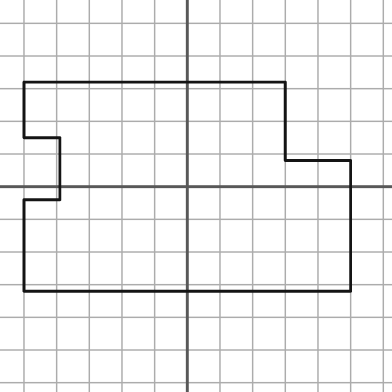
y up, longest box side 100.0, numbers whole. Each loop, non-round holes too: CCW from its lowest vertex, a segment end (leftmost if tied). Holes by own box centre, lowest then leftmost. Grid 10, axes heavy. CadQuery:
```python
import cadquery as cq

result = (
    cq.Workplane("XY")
    .moveTo(-50.0, -32.0)
    .lineTo(50.0, -32.0)
    .lineTo(50.0, 8.0)
    .lineTo(30.0, 8.0)
    .lineTo(30.0, 32.0)
    .lineTo(-50.0, 32.0)
    .lineTo(-50.0, 15.0)
    .lineTo(-39.0, 15.0)
    .lineTo(-39.0, -4.0)
    .lineTo(-50.0, -4.0)
    .close()
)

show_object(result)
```